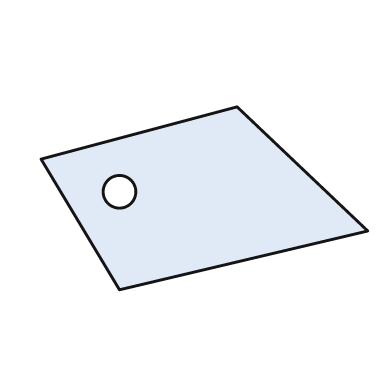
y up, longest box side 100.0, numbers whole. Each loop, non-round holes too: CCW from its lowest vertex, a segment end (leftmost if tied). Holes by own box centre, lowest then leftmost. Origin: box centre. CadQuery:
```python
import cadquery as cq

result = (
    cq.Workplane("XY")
    .moveTo(-26.0, -28.0)
    .lineTo(50.0, -10.0)
    .lineTo(10.0, 28.0)
    .lineTo(-50.0, 12.0)
    .close()
    .moveTo(-26.0, 2.0)
    .circle(5.0)
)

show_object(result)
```